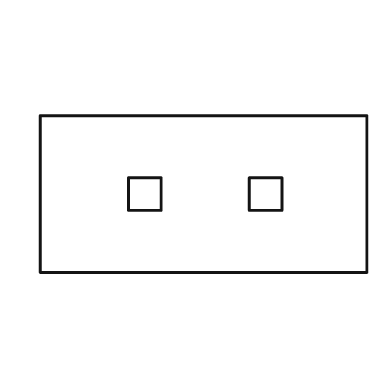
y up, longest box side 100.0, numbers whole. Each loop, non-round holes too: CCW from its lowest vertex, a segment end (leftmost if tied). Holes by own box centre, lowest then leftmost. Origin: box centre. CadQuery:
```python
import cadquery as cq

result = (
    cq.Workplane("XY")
    .moveTo(-50.0, -24.0)
    .lineTo(50.0, -24.0)
    .lineTo(50.0, 24.0)
    .lineTo(-50.0, 24.0)
    .close()
    .moveTo(-23.0, -5.0)
    .lineTo(-13.0, -5.0)
    .lineTo(-13.0, 5.0)
    .lineTo(-23.0, 5.0)
    .close()
    .moveTo(14.0, -5.0)
    .lineTo(24.0, -5.0)
    .lineTo(24.0, 5.0)
    .lineTo(14.0, 5.0)
    .close()
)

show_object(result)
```